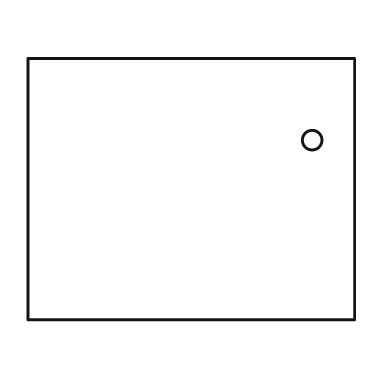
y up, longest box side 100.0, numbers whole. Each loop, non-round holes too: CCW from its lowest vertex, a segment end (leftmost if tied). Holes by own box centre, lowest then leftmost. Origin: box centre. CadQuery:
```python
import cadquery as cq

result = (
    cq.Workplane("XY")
    .moveTo(-50.0, -40.0)
    .lineTo(50.0, -40.0)
    .lineTo(50.0, 40.0)
    .lineTo(-50.0, 40.0)
    .close()
    .moveTo(37.0, 15.0)
    .circle(3.0)
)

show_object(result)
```